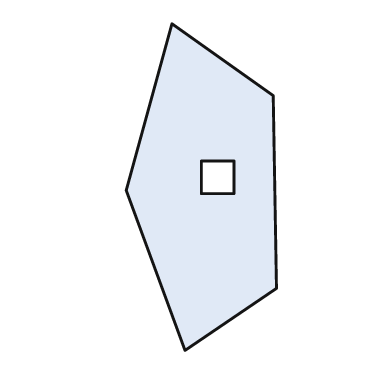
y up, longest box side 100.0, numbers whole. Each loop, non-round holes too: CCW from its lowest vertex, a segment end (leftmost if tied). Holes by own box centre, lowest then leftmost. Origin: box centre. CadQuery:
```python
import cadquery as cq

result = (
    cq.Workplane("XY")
    .moveTo(-5.0, -50.0)
    .lineTo(23.0, -31.0)
    .lineTo(22.0, 28.0)
    .lineTo(-9.0, 50.0)
    .lineTo(-23.0, -1.0)
    .close()
    .moveTo(0.0, -2.0)
    .lineTo(10.0, -2.0)
    .lineTo(10.0, 8.0)
    .lineTo(0.0, 8.0)
    .close()
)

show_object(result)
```